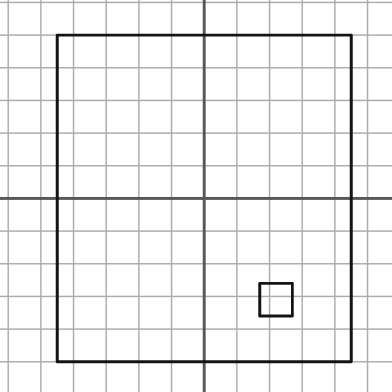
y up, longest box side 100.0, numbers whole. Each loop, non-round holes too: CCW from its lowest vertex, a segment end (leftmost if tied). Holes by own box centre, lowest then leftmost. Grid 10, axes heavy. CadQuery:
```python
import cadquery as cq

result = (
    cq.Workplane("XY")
    .moveTo(-45.0, -50.0)
    .lineTo(45.0, -50.0)
    .lineTo(45.0, 50.0)
    .lineTo(-45.0, 50.0)
    .close()
    .moveTo(17.0, -36.0)
    .lineTo(27.0, -36.0)
    .lineTo(27.0, -26.0)
    .lineTo(17.0, -26.0)
    .close()
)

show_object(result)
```